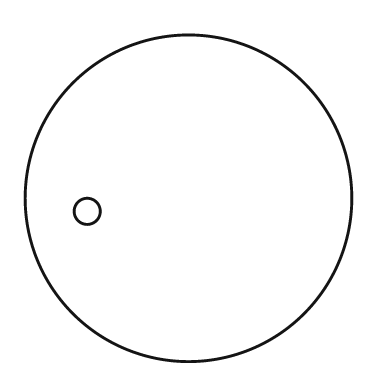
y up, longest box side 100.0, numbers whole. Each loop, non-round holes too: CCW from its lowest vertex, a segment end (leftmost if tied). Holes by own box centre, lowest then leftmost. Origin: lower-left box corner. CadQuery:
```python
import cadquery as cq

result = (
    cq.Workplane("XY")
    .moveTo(50.0, 50.0)
    .circle(50.0)
    .moveTo(19.0, 46.0)
    .circle(4.0)
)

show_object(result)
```